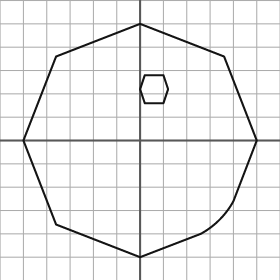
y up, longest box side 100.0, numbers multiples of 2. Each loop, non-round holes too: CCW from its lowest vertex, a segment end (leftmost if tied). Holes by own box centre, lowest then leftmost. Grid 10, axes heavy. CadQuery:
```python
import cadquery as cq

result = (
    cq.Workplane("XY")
    .moveTo(0.0, -50.0)
    .lineTo(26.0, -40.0)
    .threePointArc((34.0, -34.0), (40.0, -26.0))
    .lineTo(50.0, 0.0)
    .lineTo(36.0, 36.0)
    .lineTo(0.0, 50.0)
    .lineTo(-36.0, 36.0)
    .lineTo(-50.0, 0.0)
    .lineTo(-36.0, -36.0)
    .close()
    .moveTo(2.0, 16.0)
    .lineTo(10.0, 16.0)
    .lineTo(12.0, 22.0)
    .lineTo(10.0, 28.0)
    .lineTo(2.0, 28.0)
    .lineTo(0.0, 22.0)
    .close()
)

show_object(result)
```